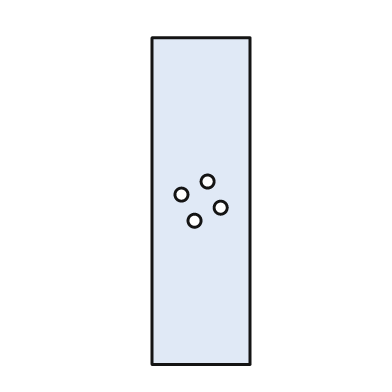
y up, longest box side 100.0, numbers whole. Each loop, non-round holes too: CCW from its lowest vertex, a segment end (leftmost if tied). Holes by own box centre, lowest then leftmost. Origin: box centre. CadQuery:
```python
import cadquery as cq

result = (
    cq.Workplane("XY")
    .moveTo(-15.0, -50.0)
    .lineTo(15.0, -50.0)
    .lineTo(15.0, 50.0)
    .lineTo(-15.0, 50.0)
    .close()
    .moveTo(-2.0, -6.0)
    .circle(2.0)
    .moveTo(6.0, -2.0)
    .circle(2.0)
    .moveTo(-6.0, 2.0)
    .circle(2.0)
    .moveTo(2.0, 6.0)
    .circle(2.0)
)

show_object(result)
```